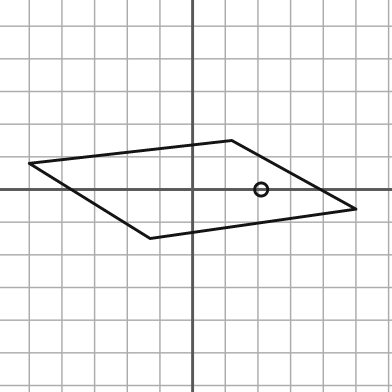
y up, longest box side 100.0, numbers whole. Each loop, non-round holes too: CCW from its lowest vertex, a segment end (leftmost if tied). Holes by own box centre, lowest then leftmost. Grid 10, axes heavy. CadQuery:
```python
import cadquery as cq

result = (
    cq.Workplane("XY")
    .moveTo(-13.0, -15.0)
    .lineTo(50.0, -6.0)
    .lineTo(12.0, 15.0)
    .lineTo(-50.0, 8.0)
    .close()
    .moveTo(21.0, 0.0)
    .circle(2.0)
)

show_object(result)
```